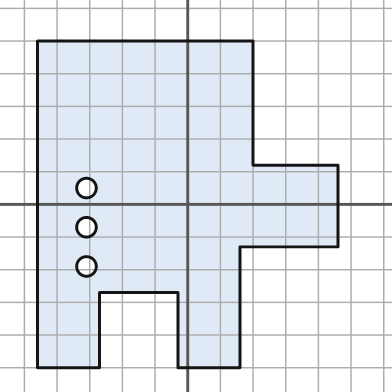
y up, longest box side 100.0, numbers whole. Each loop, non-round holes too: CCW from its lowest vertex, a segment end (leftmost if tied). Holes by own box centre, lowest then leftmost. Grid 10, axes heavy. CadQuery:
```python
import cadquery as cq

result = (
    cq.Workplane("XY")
    .moveTo(-46.0, -50.0)
    .lineTo(-27.0, -50.0)
    .lineTo(-27.0, -27.0)
    .lineTo(-3.0, -27.0)
    .lineTo(-3.0, -50.0)
    .lineTo(16.0, -50.0)
    .lineTo(16.0, -13.0)
    .lineTo(46.0, -13.0)
    .lineTo(46.0, 12.0)
    .lineTo(20.0, 12.0)
    .lineTo(20.0, 50.0)
    .lineTo(-46.0, 50.0)
    .close()
    .moveTo(-31.0, -19.0)
    .circle(3.0)
    .moveTo(-31.0, -7.0)
    .circle(3.0)
    .moveTo(-31.0, 5.0)
    .circle(3.0)
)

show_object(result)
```